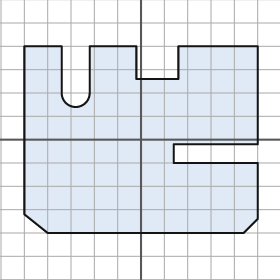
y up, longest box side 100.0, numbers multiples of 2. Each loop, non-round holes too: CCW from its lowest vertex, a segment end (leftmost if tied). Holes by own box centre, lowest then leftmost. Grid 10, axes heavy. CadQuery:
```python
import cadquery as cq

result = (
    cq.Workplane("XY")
    .moveTo(-40.0, -40.0)
    .lineTo(44.0, -40.0)
    .lineTo(50.0, -34.0)
    .lineTo(50.0, -10.0)
    .lineTo(14.0, -10.0)
    .lineTo(14.0, -2.0)
    .lineTo(50.0, -2.0)
    .lineTo(50.0, 40.0)
    .lineTo(16.0, 40.0)
    .lineTo(16.0, 26.0)
    .lineTo(-2.0, 26.0)
    .lineTo(-2.0, 40.0)
    .lineTo(-22.0, 40.0)
    .lineTo(-22.0, 20.0)
    .threePointArc((-28.0, 14.0), (-34.0, 20.0))
    .lineTo(-34.0, 40.0)
    .lineTo(-50.0, 40.0)
    .lineTo(-50.0, -32.0)
    .close()
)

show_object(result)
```